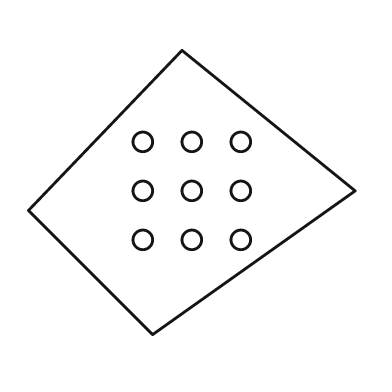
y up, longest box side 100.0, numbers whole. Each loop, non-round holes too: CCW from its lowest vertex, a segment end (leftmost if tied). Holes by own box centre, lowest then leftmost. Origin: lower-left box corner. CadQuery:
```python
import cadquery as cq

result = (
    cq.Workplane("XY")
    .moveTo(38.0, 0.0)
    .lineTo(100.0, 44.0)
    .lineTo(47.0, 87.0)
    .lineTo(0.0, 38.0)
    .close()
    .moveTo(35.0, 29.0)
    .circle(3.0)
    .moveTo(50.0, 29.0)
    .circle(3.0)
    .moveTo(65.0, 29.0)
    .circle(3.0)
    .moveTo(35.0, 44.0)
    .circle(3.0)
    .moveTo(50.0, 44.0)
    .circle(3.0)
    .moveTo(65.0, 44.0)
    .circle(3.0)
    .moveTo(35.0, 59.0)
    .circle(3.0)
    .moveTo(50.0, 59.0)
    .circle(3.0)
    .moveTo(65.0, 59.0)
    .circle(3.0)
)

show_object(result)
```